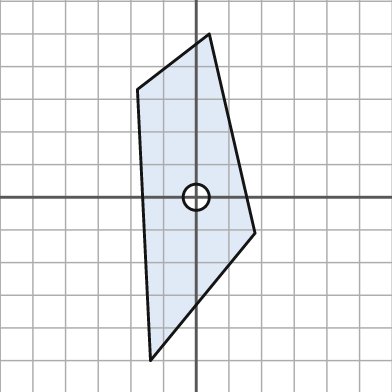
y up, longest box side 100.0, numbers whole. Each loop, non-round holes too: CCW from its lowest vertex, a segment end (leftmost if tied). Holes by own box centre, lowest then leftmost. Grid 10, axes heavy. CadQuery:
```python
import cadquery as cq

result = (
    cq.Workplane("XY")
    .moveTo(-14.0, -50.0)
    .lineTo(18.0, -11.0)
    .lineTo(4.0, 50.0)
    .lineTo(-18.0, 33.0)
    .close()
    .moveTo(0.0, 0.0)
    .circle(4.0)
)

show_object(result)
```